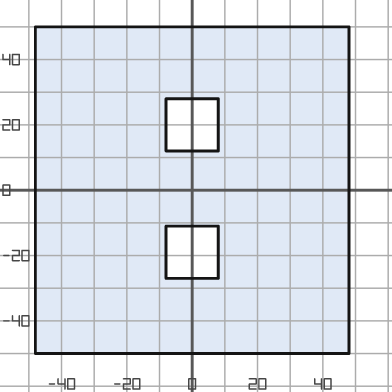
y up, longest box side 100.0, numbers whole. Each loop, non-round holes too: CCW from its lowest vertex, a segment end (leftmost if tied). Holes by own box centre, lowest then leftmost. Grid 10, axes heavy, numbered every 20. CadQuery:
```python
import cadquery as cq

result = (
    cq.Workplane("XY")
    .moveTo(-48.0, -50.0)
    .lineTo(48.0, -50.0)
    .lineTo(48.0, 50.0)
    .lineTo(-48.0, 50.0)
    .close()
    .moveTo(-8.0, -27.0)
    .lineTo(8.0, -27.0)
    .lineTo(8.0, -11.0)
    .lineTo(-8.0, -11.0)
    .close()
    .moveTo(-8.0, 12.0)
    .lineTo(8.0, 12.0)
    .lineTo(8.0, 28.0)
    .lineTo(-8.0, 28.0)
    .close()
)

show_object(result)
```